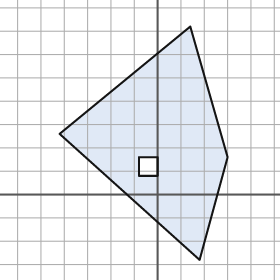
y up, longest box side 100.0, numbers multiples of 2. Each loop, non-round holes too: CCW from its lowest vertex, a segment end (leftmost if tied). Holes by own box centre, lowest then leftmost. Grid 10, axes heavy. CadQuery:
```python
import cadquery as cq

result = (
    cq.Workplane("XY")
    .moveTo(18.0, -28.0)
    .lineTo(30.0, 16.0)
    .lineTo(14.0, 72.0)
    .lineTo(-42.0, 26.0)
    .close()
    .moveTo(-8.0, 8.0)
    .lineTo(0.0, 8.0)
    .lineTo(0.0, 16.0)
    .lineTo(-8.0, 16.0)
    .close()
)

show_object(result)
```